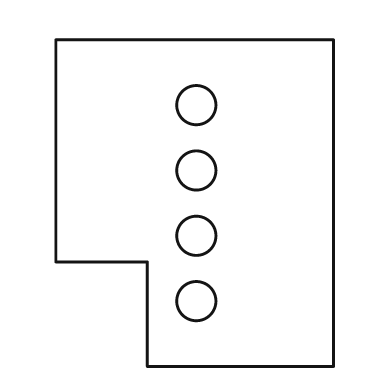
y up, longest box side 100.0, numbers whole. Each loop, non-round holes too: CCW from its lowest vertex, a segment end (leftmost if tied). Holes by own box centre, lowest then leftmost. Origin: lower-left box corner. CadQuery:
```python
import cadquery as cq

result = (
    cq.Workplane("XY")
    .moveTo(28.0, 0.0)
    .lineTo(85.0, 0.0)
    .lineTo(85.0, 100.0)
    .lineTo(0.0, 100.0)
    .lineTo(0.0, 32.0)
    .lineTo(28.0, 32.0)
    .close()
    .moveTo(43.0, 20.0)
    .circle(6.0)
    .moveTo(43.0, 40.0)
    .circle(6.0)
    .moveTo(43.0, 60.0)
    .circle(6.0)
    .moveTo(43.0, 80.0)
    .circle(6.0)
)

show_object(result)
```